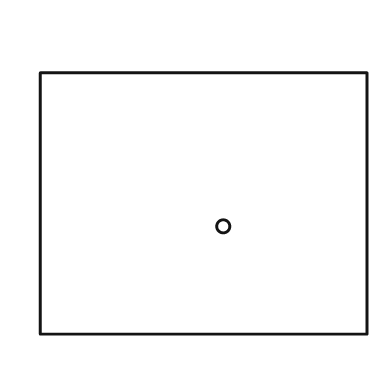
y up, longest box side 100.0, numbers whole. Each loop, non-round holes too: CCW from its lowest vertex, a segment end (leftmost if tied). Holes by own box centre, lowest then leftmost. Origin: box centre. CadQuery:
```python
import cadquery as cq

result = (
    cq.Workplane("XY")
    .moveTo(-50.0, -40.0)
    .lineTo(50.0, -40.0)
    .lineTo(50.0, 40.0)
    .lineTo(-50.0, 40.0)
    .close()
    .moveTo(6.0, -7.0)
    .circle(2.0)
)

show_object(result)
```